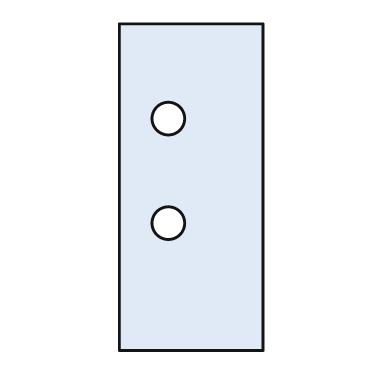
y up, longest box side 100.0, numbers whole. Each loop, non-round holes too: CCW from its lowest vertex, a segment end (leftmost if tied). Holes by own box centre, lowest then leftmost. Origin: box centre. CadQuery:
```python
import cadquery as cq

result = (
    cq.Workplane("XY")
    .moveTo(-22.0, -50.0)
    .lineTo(22.0, -50.0)
    .lineTo(22.0, 50.0)
    .lineTo(-22.0, 50.0)
    .close()
    .moveTo(-7.0, -11.0)
    .circle(5.0)
    .moveTo(-7.0, 21.0)
    .circle(5.0)
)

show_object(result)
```